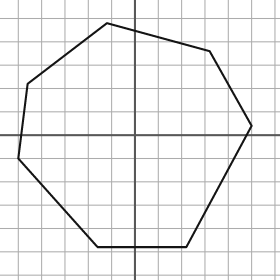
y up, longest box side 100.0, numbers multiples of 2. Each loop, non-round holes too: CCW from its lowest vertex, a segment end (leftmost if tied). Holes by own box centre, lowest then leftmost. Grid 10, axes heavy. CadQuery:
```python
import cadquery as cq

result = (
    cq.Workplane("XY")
    .moveTo(-16.0, -48.0)
    .lineTo(22.0, -48.0)
    .lineTo(50.0, 4.0)
    .lineTo(32.0, 36.0)
    .lineTo(-12.0, 48.0)
    .lineTo(-46.0, 22.0)
    .lineTo(-50.0, -10.0)
    .close()
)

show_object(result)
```